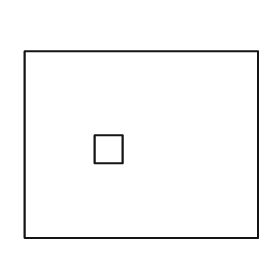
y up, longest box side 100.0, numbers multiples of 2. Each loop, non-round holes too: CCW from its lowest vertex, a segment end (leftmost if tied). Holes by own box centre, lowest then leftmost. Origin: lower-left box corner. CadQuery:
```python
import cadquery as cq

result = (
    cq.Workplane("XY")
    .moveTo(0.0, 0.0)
    .lineTo(100.0, 0.0)
    .lineTo(100.0, 80.0)
    .lineTo(0.0, 80.0)
    .close()
    .moveTo(30.0, 32.0)
    .lineTo(42.0, 32.0)
    .lineTo(42.0, 44.0)
    .lineTo(30.0, 44.0)
    .close()
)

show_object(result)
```